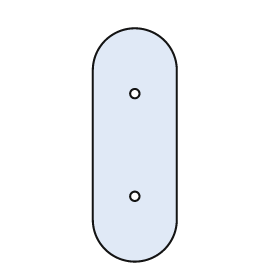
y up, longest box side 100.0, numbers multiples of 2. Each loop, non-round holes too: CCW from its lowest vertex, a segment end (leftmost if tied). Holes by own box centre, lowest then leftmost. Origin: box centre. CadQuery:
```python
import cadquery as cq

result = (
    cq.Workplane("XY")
    .moveTo(-18.0, -32.0)
    .threePointArc((0.0, -50.0), (18.0, -32.0))
    .lineTo(18.0, 32.0)
    .threePointArc((0.0, 50.0), (-18.0, 32.0))
    .close()
    .moveTo(0.0, -22.0)
    .circle(2.0)
    .moveTo(0.0, 22.0)
    .circle(2.0)
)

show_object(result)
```